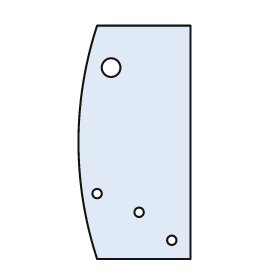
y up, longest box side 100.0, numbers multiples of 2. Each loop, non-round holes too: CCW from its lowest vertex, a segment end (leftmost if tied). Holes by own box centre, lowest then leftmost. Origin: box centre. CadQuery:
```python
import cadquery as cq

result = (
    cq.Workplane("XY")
    .moveTo(-16.0, -50.0)
    .lineTo(24.0, -50.0)
    .lineTo(24.0, 50.0)
    .lineTo(-16.0, 50.0)
    .threePointArc((-24.0, 0.0), (-16.0, -50.0))
    .close()
    .moveTo(16.0, -42.0)
    .circle(2.0)
    .moveTo(2.0, -30.0)
    .circle(2.0)
    .moveTo(-16.0, -22.0)
    .circle(2.0)
    .moveTo(-10.0, 32.0)
    .circle(4.0)
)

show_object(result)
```